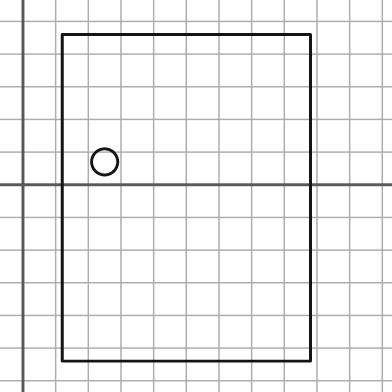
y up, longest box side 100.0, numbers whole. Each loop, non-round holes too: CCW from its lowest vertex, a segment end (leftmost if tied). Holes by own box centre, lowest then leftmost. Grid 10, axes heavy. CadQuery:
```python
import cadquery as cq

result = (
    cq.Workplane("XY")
    .moveTo(12.0, -54.0)
    .lineTo(88.0, -54.0)
    .lineTo(88.0, 46.0)
    .lineTo(12.0, 46.0)
    .close()
    .moveTo(25.0, 7.0)
    .circle(4.0)
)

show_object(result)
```